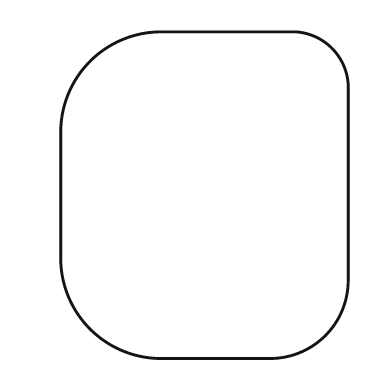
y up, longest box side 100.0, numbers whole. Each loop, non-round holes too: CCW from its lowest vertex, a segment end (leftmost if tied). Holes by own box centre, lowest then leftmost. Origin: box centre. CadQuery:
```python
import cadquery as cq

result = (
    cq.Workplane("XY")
    .moveTo(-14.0, -50.0)
    .lineTo(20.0, -50.0)
    .threePointArc((37.0, -43.0), (44.0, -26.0))
    .lineTo(44.0, 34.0)
    .threePointArc((39.0, 45.0), (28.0, 50.0))
    .lineTo(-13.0, 50.0)
    .threePointArc((-35.0, 41.0), (-44.0, 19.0))
    .lineTo(-44.0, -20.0)
    .threePointArc((-35.0, -41.0), (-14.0, -50.0))
    .close()
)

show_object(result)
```